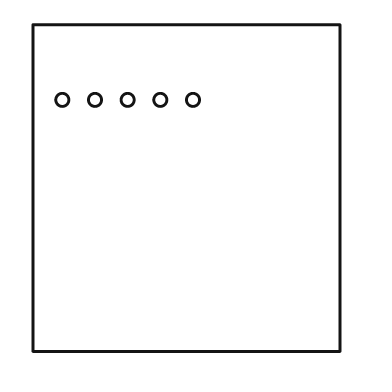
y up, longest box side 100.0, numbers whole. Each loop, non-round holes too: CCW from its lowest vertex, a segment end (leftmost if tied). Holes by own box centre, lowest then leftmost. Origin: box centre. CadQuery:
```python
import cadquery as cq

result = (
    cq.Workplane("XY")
    .moveTo(-47.0, -50.0)
    .lineTo(47.0, -50.0)
    .lineTo(47.0, 50.0)
    .lineTo(-47.0, 50.0)
    .close()
    .moveTo(-38.0, 27.0)
    .circle(2.0)
    .moveTo(-28.0, 27.0)
    .circle(2.0)
    .moveTo(-18.0, 27.0)
    .circle(2.0)
    .moveTo(-8.0, 27.0)
    .circle(2.0)
    .moveTo(2.0, 27.0)
    .circle(2.0)
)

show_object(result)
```